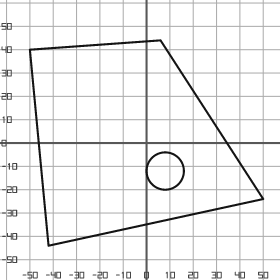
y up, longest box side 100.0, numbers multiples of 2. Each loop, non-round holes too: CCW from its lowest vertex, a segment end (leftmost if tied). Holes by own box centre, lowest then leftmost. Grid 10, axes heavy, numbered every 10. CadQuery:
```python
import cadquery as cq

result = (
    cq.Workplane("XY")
    .moveTo(-42.0, -44.0)
    .lineTo(50.0, -24.0)
    .lineTo(6.0, 44.0)
    .lineTo(-50.0, 40.0)
    .close()
    .moveTo(8.0, -12.0)
    .circle(8.0)
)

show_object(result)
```